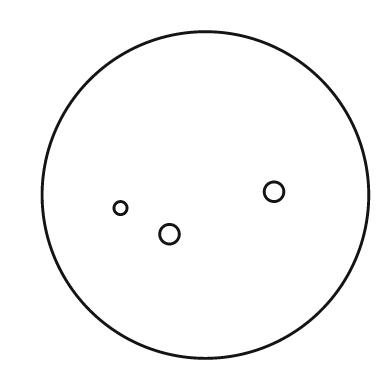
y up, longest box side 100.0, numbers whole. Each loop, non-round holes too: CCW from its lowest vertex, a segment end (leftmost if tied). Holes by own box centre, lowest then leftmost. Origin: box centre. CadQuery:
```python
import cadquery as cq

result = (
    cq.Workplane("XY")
    .moveTo(0.0, 0.0)
    .circle(50.0)
    .moveTo(-11.0, -12.0)
    .circle(3.0)
    .moveTo(-26.0, -4.0)
    .circle(2.0)
    .moveTo(21.0, 1.0)
    .circle(3.0)
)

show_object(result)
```